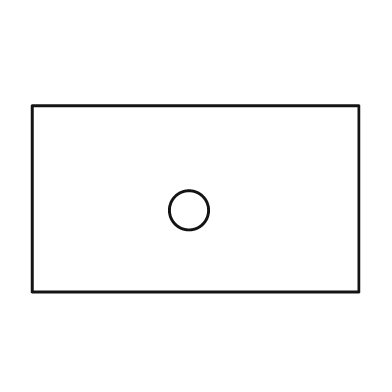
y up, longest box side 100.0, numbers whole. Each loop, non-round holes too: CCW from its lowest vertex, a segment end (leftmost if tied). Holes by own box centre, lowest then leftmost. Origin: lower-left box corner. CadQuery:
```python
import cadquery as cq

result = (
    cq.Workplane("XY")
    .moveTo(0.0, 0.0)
    .lineTo(100.0, 0.0)
    .lineTo(100.0, 57.0)
    .lineTo(0.0, 57.0)
    .close()
    .moveTo(48.0, 25.0)
    .circle(6.0)
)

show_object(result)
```